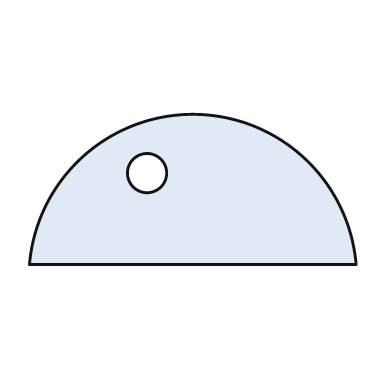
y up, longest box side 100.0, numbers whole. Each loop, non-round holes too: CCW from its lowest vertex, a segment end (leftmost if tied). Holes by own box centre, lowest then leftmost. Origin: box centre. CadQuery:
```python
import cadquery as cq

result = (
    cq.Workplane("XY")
    .moveTo(-50.0, -23.0)
    .lineTo(50.0, -23.0)
    .threePointArc((0.0, 23.0), (-50.0, -23.0))
    .close()
    .moveTo(-14.0, 5.0)
    .circle(6.0)
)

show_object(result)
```